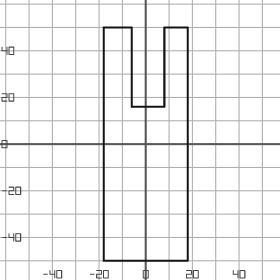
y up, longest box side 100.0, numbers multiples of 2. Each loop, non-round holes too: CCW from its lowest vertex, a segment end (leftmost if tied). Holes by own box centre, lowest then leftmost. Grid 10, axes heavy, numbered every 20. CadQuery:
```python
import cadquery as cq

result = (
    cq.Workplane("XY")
    .moveTo(-18.0, -50.0)
    .lineTo(18.0, -50.0)
    .lineTo(18.0, 50.0)
    .lineTo(8.0, 50.0)
    .lineTo(8.0, 16.0)
    .lineTo(-6.0, 16.0)
    .lineTo(-6.0, 50.0)
    .lineTo(-18.0, 50.0)
    .close()
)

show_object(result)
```